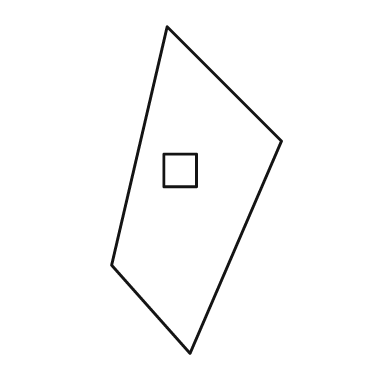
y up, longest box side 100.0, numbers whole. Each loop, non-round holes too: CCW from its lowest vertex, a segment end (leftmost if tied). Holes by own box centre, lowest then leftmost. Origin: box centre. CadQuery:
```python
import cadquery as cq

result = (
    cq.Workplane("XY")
    .moveTo(-2.0, -50.0)
    .lineTo(26.0, 15.0)
    .lineTo(-9.0, 50.0)
    .lineTo(-26.0, -23.0)
    .close()
    .moveTo(-10.0, 1.0)
    .lineTo(0.0, 1.0)
    .lineTo(0.0, 11.0)
    .lineTo(-10.0, 11.0)
    .close()
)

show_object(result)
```